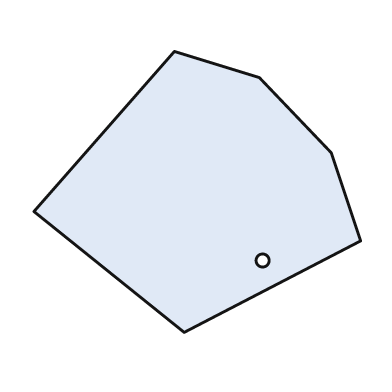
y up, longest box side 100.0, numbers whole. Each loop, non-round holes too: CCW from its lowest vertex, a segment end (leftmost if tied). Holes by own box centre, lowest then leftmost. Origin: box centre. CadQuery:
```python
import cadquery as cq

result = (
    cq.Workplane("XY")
    .moveTo(-4.0, -43.0)
    .lineTo(50.0, -15.0)
    .lineTo(41.0, 12.0)
    .lineTo(19.0, 35.0)
    .lineTo(-7.0, 43.0)
    .lineTo(-50.0, -6.0)
    .close()
    .moveTo(20.0, -21.0)
    .circle(2.0)
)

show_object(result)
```